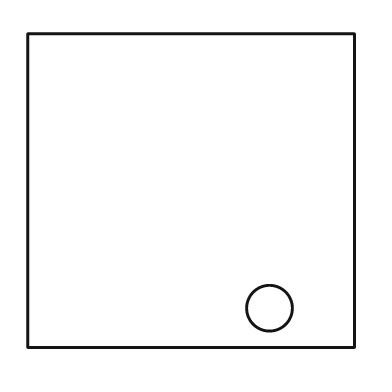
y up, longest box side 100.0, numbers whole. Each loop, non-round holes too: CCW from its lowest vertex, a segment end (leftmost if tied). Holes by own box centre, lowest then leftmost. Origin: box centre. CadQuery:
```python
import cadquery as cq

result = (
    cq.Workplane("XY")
    .moveTo(-50.0, -48.0)
    .lineTo(50.0, -48.0)
    .lineTo(50.0, 48.0)
    .lineTo(-50.0, 48.0)
    .close()
    .moveTo(24.0, -36.0)
    .circle(7.0)
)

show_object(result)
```